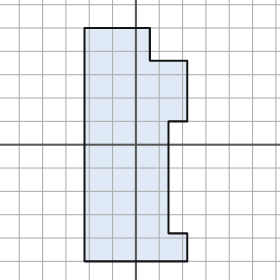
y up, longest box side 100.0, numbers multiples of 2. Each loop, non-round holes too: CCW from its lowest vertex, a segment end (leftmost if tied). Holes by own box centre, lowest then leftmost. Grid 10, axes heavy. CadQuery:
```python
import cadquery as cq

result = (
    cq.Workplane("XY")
    .moveTo(-22.0, -50.0)
    .lineTo(22.0, -50.0)
    .lineTo(22.0, -38.0)
    .lineTo(14.0, -38.0)
    .lineTo(14.0, 10.0)
    .lineTo(22.0, 10.0)
    .lineTo(22.0, 36.0)
    .lineTo(6.0, 36.0)
    .lineTo(6.0, 50.0)
    .lineTo(-22.0, 50.0)
    .close()
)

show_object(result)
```